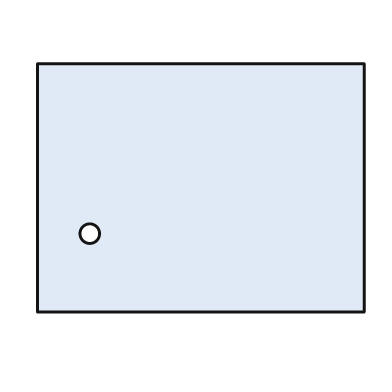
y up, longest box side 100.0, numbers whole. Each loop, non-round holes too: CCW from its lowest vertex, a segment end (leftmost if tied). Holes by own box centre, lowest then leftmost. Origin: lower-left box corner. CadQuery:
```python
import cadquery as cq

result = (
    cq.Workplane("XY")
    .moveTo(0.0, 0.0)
    .lineTo(100.0, 0.0)
    .lineTo(100.0, 76.0)
    .lineTo(0.0, 76.0)
    .close()
    .moveTo(16.0, 24.0)
    .circle(3.0)
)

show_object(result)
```